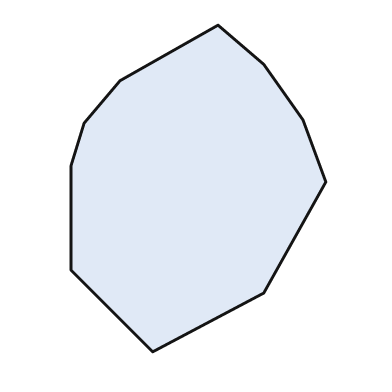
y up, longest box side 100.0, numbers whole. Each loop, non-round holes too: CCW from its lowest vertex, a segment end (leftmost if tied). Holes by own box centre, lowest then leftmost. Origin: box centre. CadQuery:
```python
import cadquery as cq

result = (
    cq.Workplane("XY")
    .moveTo(-14.0, -50.0)
    .lineTo(20.0, -32.0)
    .lineTo(39.0, 2.0)
    .lineTo(32.0, 21.0)
    .lineTo(20.0, 38.0)
    .lineTo(6.0, 50.0)
    .lineTo(-24.0, 33.0)
    .lineTo(-35.0, 20.0)
    .lineTo(-39.0, 7.0)
    .lineTo(-39.0, -25.0)
    .close()
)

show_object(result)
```